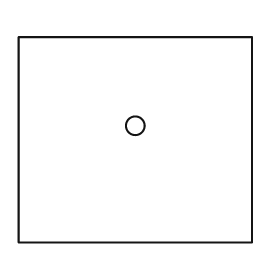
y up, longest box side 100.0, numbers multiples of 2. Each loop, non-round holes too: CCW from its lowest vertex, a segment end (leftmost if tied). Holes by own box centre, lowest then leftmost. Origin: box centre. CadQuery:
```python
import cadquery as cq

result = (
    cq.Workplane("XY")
    .moveTo(-50.0, -44.0)
    .lineTo(50.0, -44.0)
    .lineTo(50.0, 44.0)
    .lineTo(-50.0, 44.0)
    .close()
    .moveTo(0.0, 6.0)
    .circle(4.0)
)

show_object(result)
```